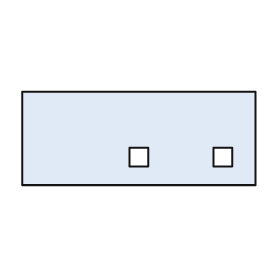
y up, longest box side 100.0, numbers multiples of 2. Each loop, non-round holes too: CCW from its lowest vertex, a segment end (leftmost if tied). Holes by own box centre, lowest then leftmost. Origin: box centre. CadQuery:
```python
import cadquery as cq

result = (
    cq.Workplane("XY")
    .moveTo(-50.0, -20.0)
    .lineTo(50.0, -20.0)
    .lineTo(50.0, 20.0)
    .lineTo(-50.0, 20.0)
    .close()
    .moveTo(-4.0, -12.0)
    .lineTo(4.0, -12.0)
    .lineTo(4.0, -4.0)
    .lineTo(-4.0, -4.0)
    .close()
    .moveTo(32.0, -12.0)
    .lineTo(40.0, -12.0)
    .lineTo(40.0, -4.0)
    .lineTo(32.0, -4.0)
    .close()
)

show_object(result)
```